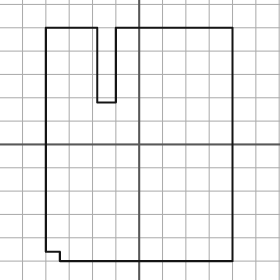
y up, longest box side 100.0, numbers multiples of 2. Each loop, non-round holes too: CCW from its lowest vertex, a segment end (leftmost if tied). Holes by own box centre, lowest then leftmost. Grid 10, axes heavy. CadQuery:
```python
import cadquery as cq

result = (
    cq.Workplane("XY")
    .moveTo(-34.0, -50.0)
    .lineTo(40.0, -50.0)
    .lineTo(40.0, 50.0)
    .lineTo(-10.0, 50.0)
    .lineTo(-10.0, 18.0)
    .lineTo(-18.0, 18.0)
    .lineTo(-18.0, 50.0)
    .lineTo(-40.0, 50.0)
    .lineTo(-40.0, -46.0)
    .lineTo(-34.0, -46.0)
    .close()
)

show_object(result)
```